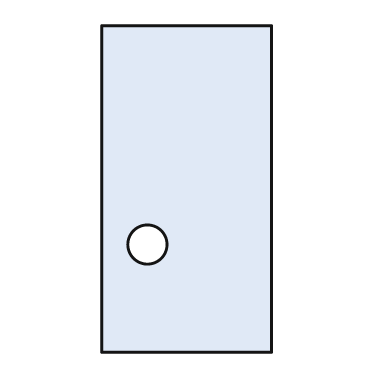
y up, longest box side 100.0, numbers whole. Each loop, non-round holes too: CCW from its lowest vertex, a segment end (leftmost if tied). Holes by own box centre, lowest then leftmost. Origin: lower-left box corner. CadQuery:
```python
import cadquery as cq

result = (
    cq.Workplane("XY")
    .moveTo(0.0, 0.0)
    .lineTo(52.0, 0.0)
    .lineTo(52.0, 100.0)
    .lineTo(0.0, 100.0)
    .close()
    .moveTo(14.0, 33.0)
    .circle(6.0)
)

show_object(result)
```